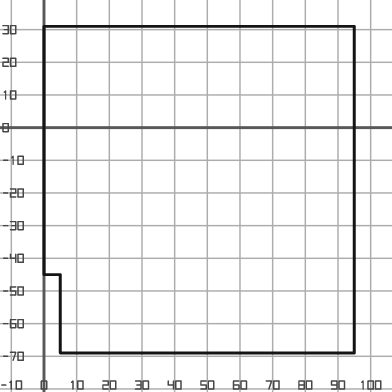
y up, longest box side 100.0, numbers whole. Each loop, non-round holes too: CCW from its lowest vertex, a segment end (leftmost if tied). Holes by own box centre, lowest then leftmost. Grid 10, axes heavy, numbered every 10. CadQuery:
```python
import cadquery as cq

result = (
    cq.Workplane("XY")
    .moveTo(5.0, -69.0)
    .lineTo(95.0, -69.0)
    .lineTo(95.0, 31.0)
    .lineTo(0.0, 31.0)
    .lineTo(0.0, -45.0)
    .lineTo(5.0, -45.0)
    .close()
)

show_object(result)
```